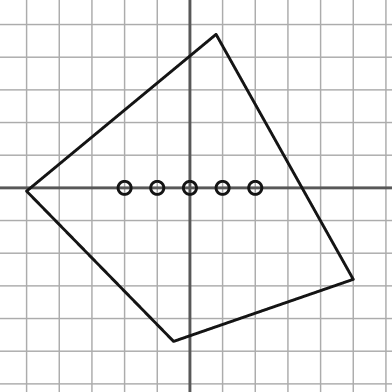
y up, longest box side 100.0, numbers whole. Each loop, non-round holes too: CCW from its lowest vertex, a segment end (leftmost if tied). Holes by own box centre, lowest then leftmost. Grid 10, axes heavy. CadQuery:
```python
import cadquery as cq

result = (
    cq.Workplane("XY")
    .moveTo(-5.0, -47.0)
    .lineTo(50.0, -28.0)
    .lineTo(8.0, 47.0)
    .lineTo(-50.0, -1.0)
    .close()
    .moveTo(-20.0, 0.0)
    .circle(2.0)
    .moveTo(-10.0, 0.0)
    .circle(2.0)
    .moveTo(0.0, 0.0)
    .circle(2.0)
    .moveTo(10.0, 0.0)
    .circle(2.0)
    .moveTo(20.0, 0.0)
    .circle(2.0)
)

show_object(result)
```